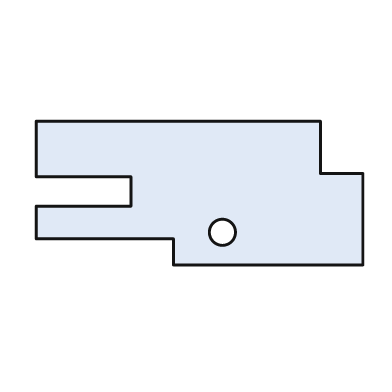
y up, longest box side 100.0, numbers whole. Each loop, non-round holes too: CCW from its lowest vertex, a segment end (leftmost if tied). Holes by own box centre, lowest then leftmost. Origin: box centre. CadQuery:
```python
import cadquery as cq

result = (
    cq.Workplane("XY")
    .moveTo(-8.0, -22.0)
    .lineTo(50.0, -22.0)
    .lineTo(50.0, 6.0)
    .lineTo(37.0, 6.0)
    .lineTo(37.0, 22.0)
    .lineTo(-50.0, 22.0)
    .lineTo(-50.0, 5.0)
    .lineTo(-21.0, 5.0)
    .lineTo(-21.0, -4.0)
    .lineTo(-50.0, -4.0)
    .lineTo(-50.0, -14.0)
    .lineTo(-8.0, -14.0)
    .close()
    .moveTo(7.0, -12.0)
    .circle(4.0)
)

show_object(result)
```